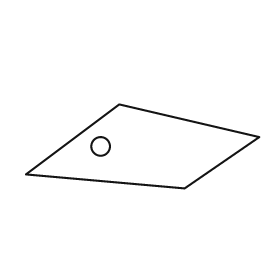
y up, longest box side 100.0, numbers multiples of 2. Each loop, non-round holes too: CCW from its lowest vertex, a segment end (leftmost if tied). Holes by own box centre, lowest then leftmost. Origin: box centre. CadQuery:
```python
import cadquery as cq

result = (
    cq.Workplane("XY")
    .moveTo(18.0, -18.0)
    .lineTo(50.0, 4.0)
    .lineTo(-10.0, 18.0)
    .lineTo(-50.0, -12.0)
    .close()
    .moveTo(-18.0, 0.0)
    .circle(4.0)
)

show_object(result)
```